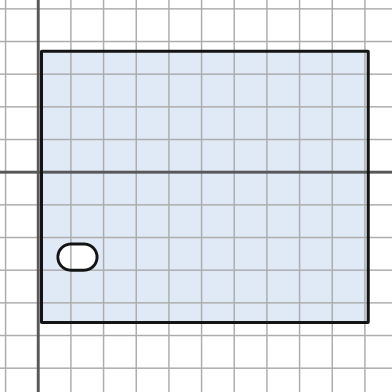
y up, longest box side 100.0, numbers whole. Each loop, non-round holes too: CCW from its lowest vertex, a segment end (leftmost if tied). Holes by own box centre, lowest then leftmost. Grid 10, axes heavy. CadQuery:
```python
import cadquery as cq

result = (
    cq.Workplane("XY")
    .moveTo(1.0, -46.0)
    .lineTo(101.0, -46.0)
    .lineTo(101.0, 37.0)
    .lineTo(1.0, 37.0)
    .close()
    .moveTo(10.0, -30.0)
    .lineTo(14.0, -30.0)
    .threePointArc((18.0, -26.0), (14.0, -22.0))
    .lineTo(10.0, -22.0)
    .threePointArc((6.0, -26.0), (10.0, -30.0))
    .close()
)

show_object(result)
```